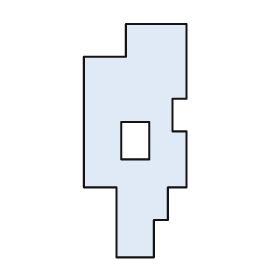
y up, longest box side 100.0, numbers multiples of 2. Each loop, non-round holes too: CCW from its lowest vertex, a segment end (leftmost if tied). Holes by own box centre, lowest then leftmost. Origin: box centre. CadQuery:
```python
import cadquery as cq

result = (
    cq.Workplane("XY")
    .moveTo(-8.0, -50.0)
    .lineTo(8.0, -50.0)
    .lineTo(8.0, -34.0)
    .lineTo(14.0, -34.0)
    .lineTo(14.0, -20.0)
    .lineTo(22.0, -20.0)
    .lineTo(22.0, 4.0)
    .lineTo(16.0, 4.0)
    .lineTo(16.0, 18.0)
    .lineTo(22.0, 18.0)
    .lineTo(22.0, 50.0)
    .lineTo(-4.0, 50.0)
    .lineTo(-4.0, 36.0)
    .lineTo(-22.0, 36.0)
    .lineTo(-22.0, -20.0)
    .lineTo(-8.0, -20.0)
    .close()
    .moveTo(-6.0, -8.0)
    .lineTo(6.0, -8.0)
    .lineTo(6.0, 8.0)
    .lineTo(-6.0, 8.0)
    .close()
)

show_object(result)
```